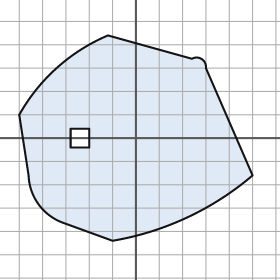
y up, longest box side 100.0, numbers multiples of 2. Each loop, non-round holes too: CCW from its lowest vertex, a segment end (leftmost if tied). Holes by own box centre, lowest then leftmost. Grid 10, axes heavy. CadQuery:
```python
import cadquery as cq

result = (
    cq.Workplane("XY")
    .moveTo(-10.0, -44.0)
    .threePointArc((22.0, -34.0), (50.0, -16.0))
    .lineTo(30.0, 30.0)
    .threePointArc((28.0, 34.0), (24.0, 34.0))
    .lineTo(-12.0, 44.0)
    .threePointArc((-34.0, 30.0), (-50.0, 10.0))
    .lineTo(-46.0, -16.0)
    .threePointArc((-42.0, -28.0), (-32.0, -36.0))
    .close()
    .moveTo(-28.0, -4.0)
    .lineTo(-20.0, -4.0)
    .lineTo(-20.0, 4.0)
    .lineTo(-28.0, 4.0)
    .close()
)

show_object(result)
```